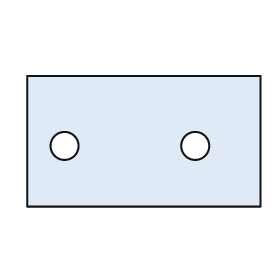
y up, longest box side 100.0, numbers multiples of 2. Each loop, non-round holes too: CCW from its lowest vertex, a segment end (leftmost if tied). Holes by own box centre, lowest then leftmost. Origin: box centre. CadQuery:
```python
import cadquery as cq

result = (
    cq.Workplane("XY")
    .moveTo(-50.0, -28.0)
    .lineTo(50.0, -28.0)
    .lineTo(50.0, 28.0)
    .lineTo(-50.0, 28.0)
    .close()
    .moveTo(-34.0, -2.0)
    .circle(6.0)
    .moveTo(22.0, -2.0)
    .circle(6.0)
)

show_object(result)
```